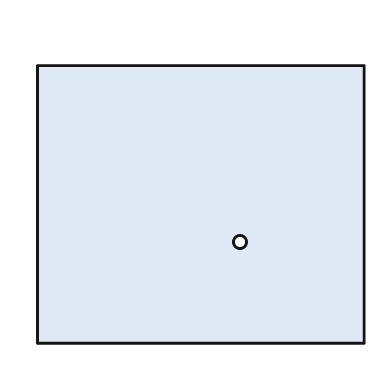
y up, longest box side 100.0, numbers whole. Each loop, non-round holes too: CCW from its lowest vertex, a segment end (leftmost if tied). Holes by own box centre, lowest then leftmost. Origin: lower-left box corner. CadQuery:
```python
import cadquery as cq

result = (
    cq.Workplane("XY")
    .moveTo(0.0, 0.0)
    .lineTo(100.0, 0.0)
    .lineTo(100.0, 85.0)
    .lineTo(0.0, 85.0)
    .close()
    .moveTo(62.0, 31.0)
    .circle(2.0)
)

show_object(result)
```